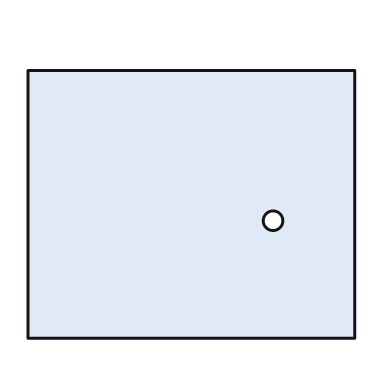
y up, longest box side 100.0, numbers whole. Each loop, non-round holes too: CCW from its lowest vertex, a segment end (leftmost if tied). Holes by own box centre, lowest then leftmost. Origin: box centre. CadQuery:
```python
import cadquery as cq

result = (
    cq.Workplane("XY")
    .moveTo(-50.0, -41.0)
    .lineTo(50.0, -41.0)
    .lineTo(50.0, 41.0)
    .lineTo(-50.0, 41.0)
    .close()
    .moveTo(25.0, -5.0)
    .circle(3.0)
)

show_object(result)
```